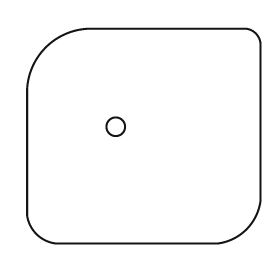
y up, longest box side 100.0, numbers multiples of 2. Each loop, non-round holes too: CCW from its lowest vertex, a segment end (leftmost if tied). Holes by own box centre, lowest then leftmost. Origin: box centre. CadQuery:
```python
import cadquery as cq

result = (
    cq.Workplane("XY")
    .moveTo(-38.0, -46.0)
    .lineTo(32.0, -46.0)
    .threePointArc((44.0, -40.0), (50.0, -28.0))
    .lineTo(50.0, 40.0)
    .threePointArc((48.0, 44.0), (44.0, 46.0))
    .lineTo(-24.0, 46.0)
    .threePointArc((-42.0, 38.0), (-50.0, 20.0))
    .lineTo(-50.0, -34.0)
    .threePointArc((-46.0, -42.0), (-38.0, -46.0))
    .close()
    .moveTo(-12.0, 4.0)
    .circle(4.0)
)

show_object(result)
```